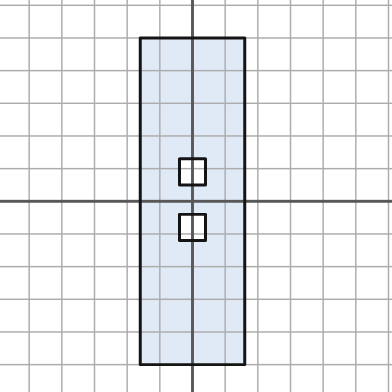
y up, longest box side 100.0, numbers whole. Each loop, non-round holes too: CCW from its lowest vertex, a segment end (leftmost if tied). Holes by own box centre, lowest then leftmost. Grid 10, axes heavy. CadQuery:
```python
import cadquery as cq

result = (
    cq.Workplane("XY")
    .moveTo(-16.0, -50.0)
    .lineTo(16.0, -50.0)
    .lineTo(16.0, 50.0)
    .lineTo(-16.0, 50.0)
    .close()
    .moveTo(-4.0, -12.0)
    .lineTo(4.0, -12.0)
    .lineTo(4.0, -4.0)
    .lineTo(-4.0, -4.0)
    .close()
    .moveTo(-4.0, 5.0)
    .lineTo(4.0, 5.0)
    .lineTo(4.0, 13.0)
    .lineTo(-4.0, 13.0)
    .close()
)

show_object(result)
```